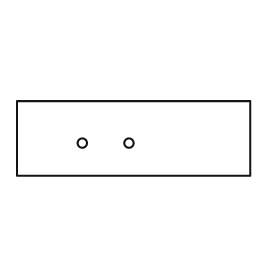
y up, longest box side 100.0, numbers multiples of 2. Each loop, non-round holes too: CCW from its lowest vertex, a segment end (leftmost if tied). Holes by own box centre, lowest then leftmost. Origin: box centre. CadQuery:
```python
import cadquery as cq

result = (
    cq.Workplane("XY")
    .moveTo(-50.0, -16.0)
    .lineTo(50.0, -16.0)
    .lineTo(50.0, 16.0)
    .lineTo(-50.0, 16.0)
    .close()
    .moveTo(-22.0, -2.0)
    .circle(2.0)
    .moveTo(-2.0, -2.0)
    .circle(2.0)
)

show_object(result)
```